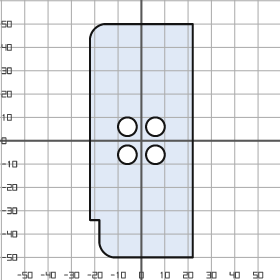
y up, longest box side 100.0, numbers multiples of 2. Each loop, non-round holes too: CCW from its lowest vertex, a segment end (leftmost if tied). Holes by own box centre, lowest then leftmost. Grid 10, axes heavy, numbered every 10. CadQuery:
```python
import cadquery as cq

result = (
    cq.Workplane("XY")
    .moveTo(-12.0, -50.0)
    .lineTo(22.0, -50.0)
    .lineTo(22.0, 50.0)
    .lineTo(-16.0, 50.0)
    .threePointArc((-20.0, 48.0), (-22.0, 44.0))
    .lineTo(-22.0, -34.0)
    .lineTo(-18.0, -34.0)
    .lineTo(-18.0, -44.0)
    .threePointArc((-16.0, -48.0), (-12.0, -50.0))
    .close()
    .moveTo(-6.0, -6.0)
    .circle(4.0)
    .moveTo(6.0, -6.0)
    .circle(4.0)
    .moveTo(-6.0, 6.0)
    .circle(4.0)
    .moveTo(6.0, 6.0)
    .circle(4.0)
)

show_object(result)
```